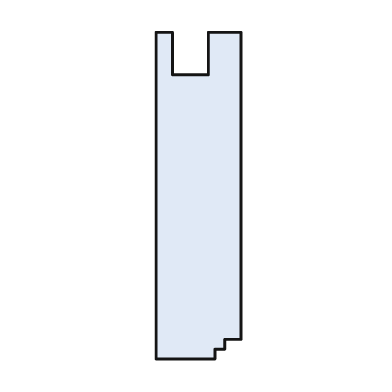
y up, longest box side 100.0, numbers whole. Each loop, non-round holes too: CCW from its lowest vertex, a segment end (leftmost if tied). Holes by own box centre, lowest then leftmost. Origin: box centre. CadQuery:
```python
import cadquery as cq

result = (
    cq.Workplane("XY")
    .moveTo(-13.0, -50.0)
    .lineTo(5.0, -50.0)
    .lineTo(5.0, -47.0)
    .lineTo(8.0, -47.0)
    .lineTo(8.0, -44.0)
    .lineTo(13.0, -44.0)
    .lineTo(13.0, 50.0)
    .lineTo(3.0, 50.0)
    .lineTo(3.0, 37.0)
    .lineTo(-8.0, 37.0)
    .lineTo(-8.0, 50.0)
    .lineTo(-13.0, 50.0)
    .close()
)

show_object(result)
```